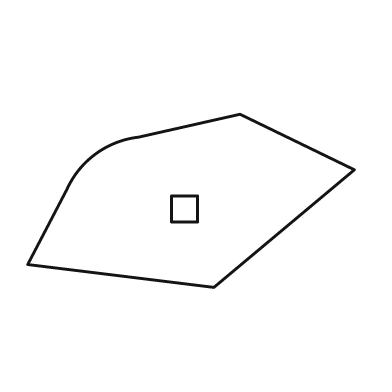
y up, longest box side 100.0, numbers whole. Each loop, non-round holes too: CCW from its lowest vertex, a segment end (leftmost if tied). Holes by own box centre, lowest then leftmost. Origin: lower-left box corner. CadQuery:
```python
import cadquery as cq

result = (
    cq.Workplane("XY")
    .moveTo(57.0, 0.0)
    .lineTo(100.0, 36.0)
    .lineTo(65.0, 53.0)
    .lineTo(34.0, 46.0)
    .threePointArc((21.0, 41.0), (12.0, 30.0))
    .lineTo(0.0, 7.0)
    .close()
    .moveTo(44.0, 20.0)
    .lineTo(52.0, 20.0)
    .lineTo(52.0, 28.0)
    .lineTo(44.0, 28.0)
    .close()
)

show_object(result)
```